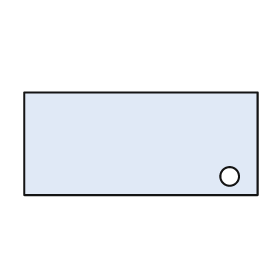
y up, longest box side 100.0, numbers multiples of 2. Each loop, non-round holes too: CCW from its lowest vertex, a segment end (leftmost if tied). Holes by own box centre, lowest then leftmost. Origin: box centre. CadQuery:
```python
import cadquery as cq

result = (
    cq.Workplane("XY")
    .moveTo(-50.0, -22.0)
    .lineTo(50.0, -22.0)
    .lineTo(50.0, 22.0)
    .lineTo(-50.0, 22.0)
    .close()
    .moveTo(38.0, -14.0)
    .circle(4.0)
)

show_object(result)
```